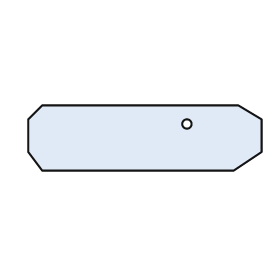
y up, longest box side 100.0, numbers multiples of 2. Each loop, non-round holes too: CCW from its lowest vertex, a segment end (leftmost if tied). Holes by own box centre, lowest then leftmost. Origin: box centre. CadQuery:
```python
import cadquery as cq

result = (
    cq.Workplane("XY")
    .moveTo(-44.0, -14.0)
    .lineTo(38.0, -14.0)
    .lineTo(50.0, -6.0)
    .lineTo(50.0, 8.0)
    .lineTo(40.0, 14.0)
    .lineTo(-44.0, 14.0)
    .lineTo(-50.0, 8.0)
    .lineTo(-50.0, -6.0)
    .close()
    .moveTo(18.0, 6.0)
    .circle(2.0)
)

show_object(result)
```